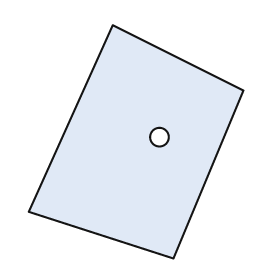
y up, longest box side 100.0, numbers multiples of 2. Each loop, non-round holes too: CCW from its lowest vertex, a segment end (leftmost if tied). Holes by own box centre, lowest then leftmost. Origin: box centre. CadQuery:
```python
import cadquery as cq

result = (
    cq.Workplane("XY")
    .moveTo(16.0, -50.0)
    .lineTo(46.0, 22.0)
    .lineTo(-10.0, 50.0)
    .lineTo(-46.0, -30.0)
    .close()
    .moveTo(10.0, 2.0)
    .circle(4.0)
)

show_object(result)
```